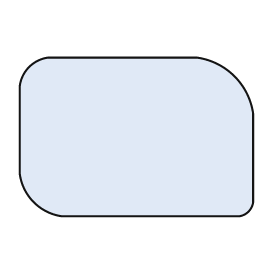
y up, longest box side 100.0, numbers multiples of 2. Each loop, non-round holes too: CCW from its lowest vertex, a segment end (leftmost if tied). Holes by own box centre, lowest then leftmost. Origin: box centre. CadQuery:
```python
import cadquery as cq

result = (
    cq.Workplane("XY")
    .moveTo(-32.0, -34.0)
    .lineTo(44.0, -34.0)
    .threePointArc((48.0, -32.0), (50.0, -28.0))
    .lineTo(50.0, 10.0)
    .threePointArc((42.0, 26.0), (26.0, 34.0))
    .lineTo(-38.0, 34.0)
    .threePointArc((-46.0, 30.0), (-50.0, 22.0))
    .lineTo(-50.0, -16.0)
    .threePointArc((-44.0, -28.0), (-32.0, -34.0))
    .close()
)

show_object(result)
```